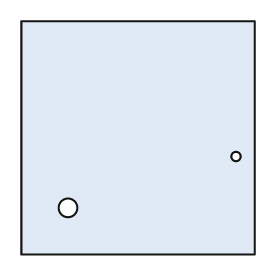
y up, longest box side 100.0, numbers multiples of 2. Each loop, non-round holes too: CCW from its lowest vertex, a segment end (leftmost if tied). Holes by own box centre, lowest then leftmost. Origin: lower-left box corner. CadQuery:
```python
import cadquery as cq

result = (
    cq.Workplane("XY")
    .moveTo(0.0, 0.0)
    .lineTo(100.0, 0.0)
    .lineTo(100.0, 100.0)
    .lineTo(0.0, 100.0)
    .close()
    .moveTo(20.0, 20.0)
    .circle(4.0)
    .moveTo(92.0, 42.0)
    .circle(2.0)
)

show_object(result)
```